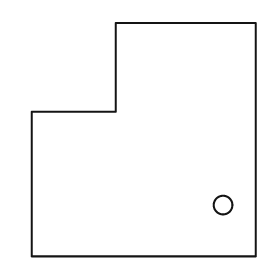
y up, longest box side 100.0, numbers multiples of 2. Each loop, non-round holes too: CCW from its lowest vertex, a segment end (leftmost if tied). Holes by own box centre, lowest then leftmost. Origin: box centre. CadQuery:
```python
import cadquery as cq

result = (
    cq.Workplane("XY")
    .moveTo(-48.0, -50.0)
    .lineTo(48.0, -50.0)
    .lineTo(48.0, 50.0)
    .lineTo(-12.0, 50.0)
    .lineTo(-12.0, 12.0)
    .lineTo(-48.0, 12.0)
    .close()
    .moveTo(34.0, -28.0)
    .circle(4.0)
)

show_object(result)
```